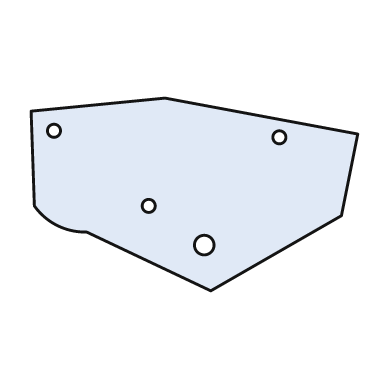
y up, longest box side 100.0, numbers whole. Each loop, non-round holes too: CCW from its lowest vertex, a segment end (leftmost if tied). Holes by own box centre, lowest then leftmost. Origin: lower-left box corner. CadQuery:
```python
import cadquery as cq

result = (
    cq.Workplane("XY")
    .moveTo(55.0, 0.0)
    .lineTo(95.0, 23.0)
    .lineTo(100.0, 48.0)
    .lineTo(41.0, 59.0)
    .lineTo(0.0, 55.0)
    .lineTo(1.0, 26.0)
    .threePointArc((8.0, 20.0), (17.0, 18.0))
    .close()
    .moveTo(53.0, 14.0)
    .circle(3.0)
    .moveTo(36.0, 26.0)
    .circle(2.0)
    .moveTo(76.0, 47.0)
    .circle(2.0)
    .moveTo(7.0, 49.0)
    .circle(2.0)
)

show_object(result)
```